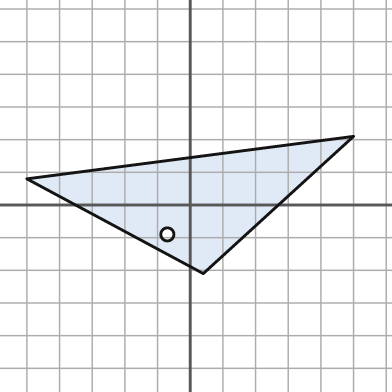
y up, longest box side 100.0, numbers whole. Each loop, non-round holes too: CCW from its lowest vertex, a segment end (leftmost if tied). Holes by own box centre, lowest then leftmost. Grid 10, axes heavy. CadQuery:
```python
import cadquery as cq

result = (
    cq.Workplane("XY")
    .moveTo(4.0, -21.0)
    .lineTo(50.0, 21.0)
    .lineTo(-50.0, 8.0)
    .close()
    .moveTo(-7.0, -9.0)
    .circle(2.0)
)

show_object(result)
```